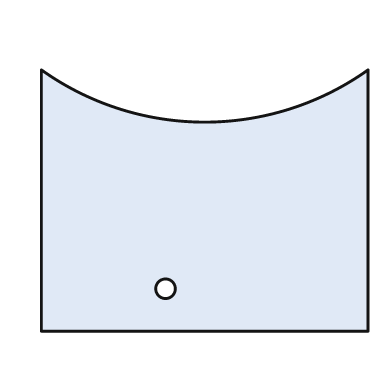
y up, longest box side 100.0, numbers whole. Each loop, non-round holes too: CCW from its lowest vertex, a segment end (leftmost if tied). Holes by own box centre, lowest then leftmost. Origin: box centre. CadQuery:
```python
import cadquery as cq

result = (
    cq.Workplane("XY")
    .moveTo(-50.0, -40.0)
    .lineTo(50.0, -40.0)
    .lineTo(50.0, 40.0)
    .threePointArc((0.0, 24.0), (-50.0, 40.0))
    .close()
    .moveTo(-12.0, -27.0)
    .circle(3.0)
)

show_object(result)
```